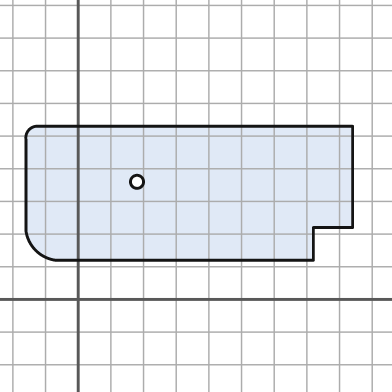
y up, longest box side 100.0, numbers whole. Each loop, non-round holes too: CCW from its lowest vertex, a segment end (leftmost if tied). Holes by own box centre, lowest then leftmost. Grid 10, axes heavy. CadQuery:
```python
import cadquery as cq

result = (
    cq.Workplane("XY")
    .moveTo(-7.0, 12.0)
    .lineTo(72.0, 12.0)
    .lineTo(72.0, 22.0)
    .lineTo(84.0, 22.0)
    .lineTo(84.0, 53.0)
    .lineTo(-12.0, 53.0)
    .threePointArc((-15.0, 52.0), (-16.0, 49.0))
    .lineTo(-16.0, 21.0)
    .threePointArc((-13.0, 15.0), (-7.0, 12.0))
    .close()
    .moveTo(18.0, 36.0)
    .circle(2.0)
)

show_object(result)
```